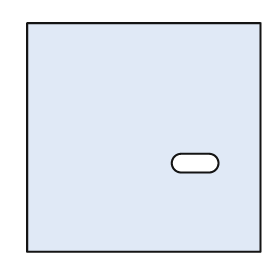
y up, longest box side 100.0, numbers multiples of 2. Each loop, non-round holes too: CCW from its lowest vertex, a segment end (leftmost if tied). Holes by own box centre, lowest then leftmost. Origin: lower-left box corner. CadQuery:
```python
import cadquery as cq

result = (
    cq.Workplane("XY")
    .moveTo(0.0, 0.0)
    .lineTo(100.0, 0.0)
    .lineTo(100.0, 98.0)
    .lineTo(0.0, 98.0)
    .close()
    .moveTo(66.0, 34.0)
    .lineTo(78.0, 34.0)
    .threePointArc((82.0, 38.0), (78.0, 42.0))
    .lineTo(66.0, 42.0)
    .threePointArc((62.0, 38.0), (66.0, 34.0))
    .close()
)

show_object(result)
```